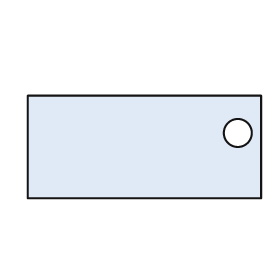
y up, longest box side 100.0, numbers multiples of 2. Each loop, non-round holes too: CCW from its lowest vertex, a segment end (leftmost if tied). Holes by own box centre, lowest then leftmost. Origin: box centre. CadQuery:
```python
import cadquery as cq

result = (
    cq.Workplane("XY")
    .moveTo(-50.0, -22.0)
    .lineTo(50.0, -22.0)
    .lineTo(50.0, 22.0)
    .lineTo(-50.0, 22.0)
    .close()
    .moveTo(40.0, 6.0)
    .circle(6.0)
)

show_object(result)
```